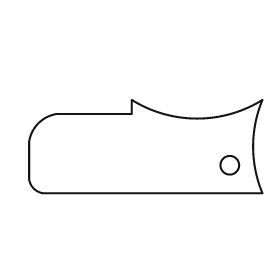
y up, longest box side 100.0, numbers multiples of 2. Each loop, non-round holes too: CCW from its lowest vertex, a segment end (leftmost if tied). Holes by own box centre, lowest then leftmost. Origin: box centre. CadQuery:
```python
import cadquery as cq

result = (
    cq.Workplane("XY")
    .moveTo(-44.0, -20.0)
    .lineTo(50.0, -20.0)
    .threePointArc((46.0, 0.0), (50.0, 20.0))
    .threePointArc((22.0, 12.0), (-6.0, 20.0))
    .lineTo(-6.0, 14.0)
    .lineTo(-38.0, 14.0)
    .threePointArc((-46.0, 10.0), (-50.0, 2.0))
    .lineTo(-50.0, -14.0)
    .threePointArc((-48.0, -18.0), (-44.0, -20.0))
    .close()
    .moveTo(36.0, -8.0)
    .circle(4.0)
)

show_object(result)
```